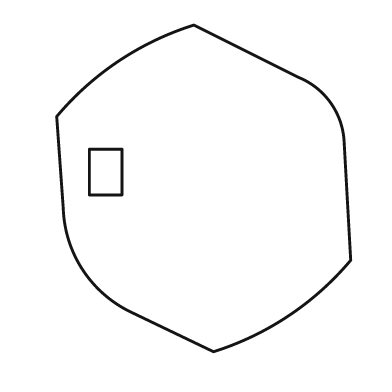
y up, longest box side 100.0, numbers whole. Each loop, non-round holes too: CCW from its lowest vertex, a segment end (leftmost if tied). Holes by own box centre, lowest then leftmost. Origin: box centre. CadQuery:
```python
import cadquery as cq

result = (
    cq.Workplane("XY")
    .moveTo(3.0, -50.0)
    .threePointArc((26.0, -39.0), (45.0, -22.0))
    .lineTo(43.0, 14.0)
    .threePointArc((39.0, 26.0), (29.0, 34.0))
    .lineTo(-3.0, 50.0)
    .threePointArc((-26.0, 39.0), (-45.0, 22.0))
    .lineTo(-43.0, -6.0)
    .threePointArc((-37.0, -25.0), (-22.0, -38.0))
    .close()
    .moveTo(-35.0, -2.0)
    .lineTo(-25.0, -2.0)
    .lineTo(-25.0, 12.0)
    .lineTo(-35.0, 12.0)
    .close()
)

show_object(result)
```